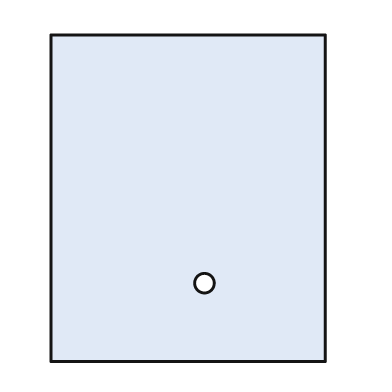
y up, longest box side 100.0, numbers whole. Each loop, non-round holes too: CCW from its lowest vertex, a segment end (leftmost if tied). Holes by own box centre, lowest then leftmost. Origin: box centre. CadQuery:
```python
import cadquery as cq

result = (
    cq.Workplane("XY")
    .moveTo(-42.0, -50.0)
    .lineTo(42.0, -50.0)
    .lineTo(42.0, 50.0)
    .lineTo(-42.0, 50.0)
    .close()
    .moveTo(5.0, -26.0)
    .circle(3.0)
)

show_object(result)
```